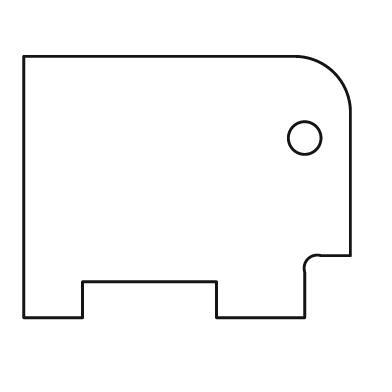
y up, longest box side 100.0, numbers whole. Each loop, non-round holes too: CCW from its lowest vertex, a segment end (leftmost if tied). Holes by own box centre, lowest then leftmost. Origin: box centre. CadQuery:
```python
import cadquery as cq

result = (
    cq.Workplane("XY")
    .moveTo(-50.0, -40.0)
    .lineTo(-32.0, -40.0)
    .lineTo(-32.0, -29.0)
    .lineTo(9.0, -29.0)
    .lineTo(9.0, -40.0)
    .lineTo(36.0, -40.0)
    .lineTo(36.0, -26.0)
    .threePointArc((37.0, -22.0), (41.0, -21.0))
    .lineTo(50.0, -21.0)
    .lineTo(50.0, 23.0)
    .threePointArc((45.0, 35.0), (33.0, 40.0))
    .lineTo(-50.0, 40.0)
    .close()
    .moveTo(36.0, 15.0)
    .circle(5.0)
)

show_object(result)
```